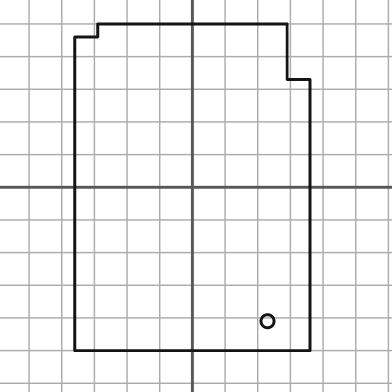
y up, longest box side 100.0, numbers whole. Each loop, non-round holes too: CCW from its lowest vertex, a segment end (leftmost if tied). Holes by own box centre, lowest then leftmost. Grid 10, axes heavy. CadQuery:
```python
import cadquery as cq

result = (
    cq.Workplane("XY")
    .moveTo(-36.0, -50.0)
    .lineTo(36.0, -50.0)
    .lineTo(36.0, 33.0)
    .lineTo(29.0, 33.0)
    .lineTo(29.0, 50.0)
    .lineTo(-29.0, 50.0)
    .lineTo(-29.0, 46.0)
    .lineTo(-36.0, 46.0)
    .close()
    .moveTo(23.0, -41.0)
    .circle(2.0)
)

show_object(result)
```